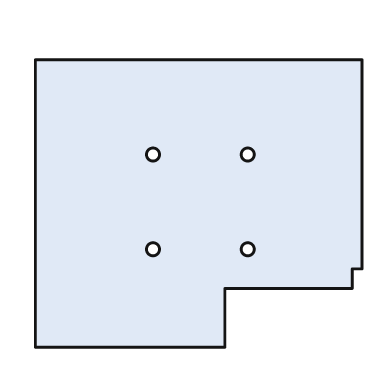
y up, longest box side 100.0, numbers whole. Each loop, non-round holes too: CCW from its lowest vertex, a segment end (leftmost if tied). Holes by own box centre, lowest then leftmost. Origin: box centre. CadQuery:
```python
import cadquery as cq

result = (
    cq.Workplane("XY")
    .moveTo(-50.0, -44.0)
    .lineTo(8.0, -44.0)
    .lineTo(8.0, -26.0)
    .lineTo(47.0, -26.0)
    .lineTo(47.0, -20.0)
    .lineTo(50.0, -20.0)
    .lineTo(50.0, 44.0)
    .lineTo(-50.0, 44.0)
    .close()
    .moveTo(-14.0, -14.0)
    .circle(2.0)
    .moveTo(15.0, -14.0)
    .circle(2.0)
    .moveTo(-14.0, 15.0)
    .circle(2.0)
    .moveTo(15.0, 15.0)
    .circle(2.0)
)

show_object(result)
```